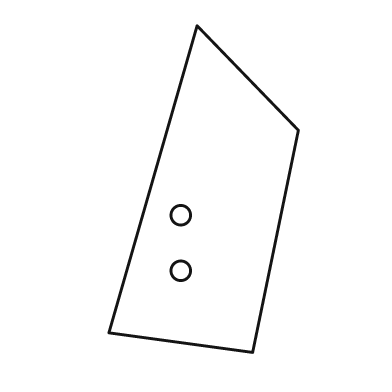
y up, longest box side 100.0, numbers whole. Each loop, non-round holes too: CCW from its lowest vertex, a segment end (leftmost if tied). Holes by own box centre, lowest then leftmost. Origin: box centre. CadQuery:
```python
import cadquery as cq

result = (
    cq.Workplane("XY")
    .moveTo(15.0, -50.0)
    .lineTo(29.0, 18.0)
    .lineTo(-2.0, 50.0)
    .lineTo(-29.0, -44.0)
    .close()
    .moveTo(-7.0, -25.0)
    .circle(3.0)
    .moveTo(-7.0, -8.0)
    .circle(3.0)
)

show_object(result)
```